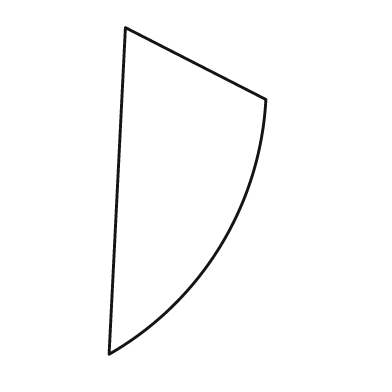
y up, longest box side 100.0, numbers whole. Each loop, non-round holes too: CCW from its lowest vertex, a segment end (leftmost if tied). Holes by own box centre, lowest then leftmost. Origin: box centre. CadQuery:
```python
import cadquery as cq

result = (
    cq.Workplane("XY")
    .moveTo(-24.0, -50.0)
    .threePointArc((10.0, -17.0), (24.0, 28.0))
    .lineTo(-19.0, 50.0)
    .close()
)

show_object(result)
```